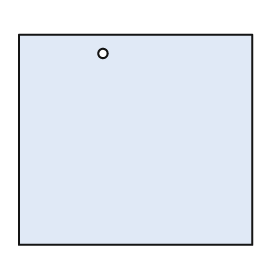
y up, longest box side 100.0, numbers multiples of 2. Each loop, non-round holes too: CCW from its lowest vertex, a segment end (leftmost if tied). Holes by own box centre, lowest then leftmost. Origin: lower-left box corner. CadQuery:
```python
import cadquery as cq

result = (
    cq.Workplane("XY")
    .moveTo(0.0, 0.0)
    .lineTo(100.0, 0.0)
    .lineTo(100.0, 90.0)
    .lineTo(0.0, 90.0)
    .close()
    .moveTo(36.0, 82.0)
    .circle(2.0)
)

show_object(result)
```